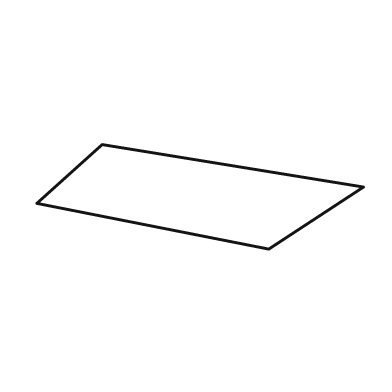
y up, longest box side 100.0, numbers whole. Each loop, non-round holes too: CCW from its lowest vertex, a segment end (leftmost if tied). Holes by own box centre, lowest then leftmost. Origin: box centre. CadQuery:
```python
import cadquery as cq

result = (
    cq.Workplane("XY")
    .moveTo(21.0, -16.0)
    .lineTo(50.0, 3.0)
    .lineTo(-30.0, 16.0)
    .lineTo(-50.0, -2.0)
    .close()
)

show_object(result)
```